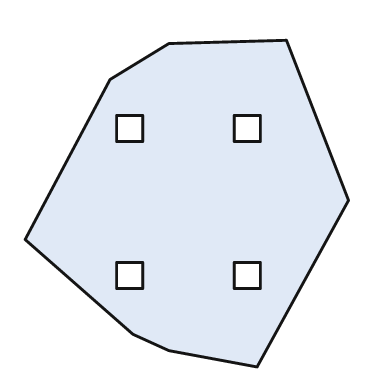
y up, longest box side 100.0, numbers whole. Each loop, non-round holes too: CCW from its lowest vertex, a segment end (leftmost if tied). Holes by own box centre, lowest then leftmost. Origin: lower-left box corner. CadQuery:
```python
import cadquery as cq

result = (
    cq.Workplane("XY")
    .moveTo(71.0, 0.0)
    .lineTo(99.0, 51.0)
    .lineTo(80.0, 100.0)
    .lineTo(44.0, 99.0)
    .lineTo(26.0, 88.0)
    .lineTo(0.0, 39.0)
    .lineTo(33.0, 10.0)
    .lineTo(44.0, 5.0)
    .close()
    .moveTo(28.0, 24.0)
    .lineTo(36.0, 24.0)
    .lineTo(36.0, 32.0)
    .lineTo(28.0, 32.0)
    .close()
    .moveTo(64.0, 24.0)
    .lineTo(72.0, 24.0)
    .lineTo(72.0, 32.0)
    .lineTo(64.0, 32.0)
    .close()
    .moveTo(28.0, 69.0)
    .lineTo(36.0, 69.0)
    .lineTo(36.0, 77.0)
    .lineTo(28.0, 77.0)
    .close()
    .moveTo(64.0, 69.0)
    .lineTo(72.0, 69.0)
    .lineTo(72.0, 77.0)
    .lineTo(64.0, 77.0)
    .close()
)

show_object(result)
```